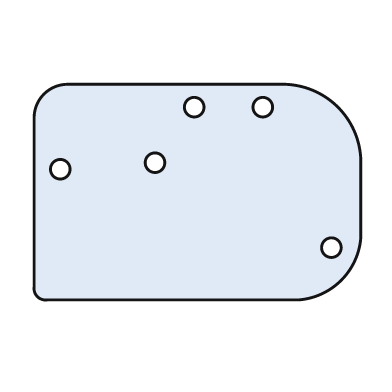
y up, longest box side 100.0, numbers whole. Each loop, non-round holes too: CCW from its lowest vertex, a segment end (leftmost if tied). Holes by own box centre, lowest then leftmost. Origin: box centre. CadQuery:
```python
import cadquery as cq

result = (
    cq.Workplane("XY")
    .moveTo(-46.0, -33.0)
    .lineTo(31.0, -33.0)
    .threePointArc((44.0, -27.0), (50.0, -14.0))
    .lineTo(50.0, 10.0)
    .threePointArc((43.0, 26.0), (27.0, 33.0))
    .lineTo(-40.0, 33.0)
    .threePointArc((-47.0, 30.0), (-50.0, 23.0))
    .lineTo(-50.0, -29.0)
    .threePointArc((-49.0, -32.0), (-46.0, -33.0))
    .close()
    .moveTo(41.0, -17.0)
    .circle(3.0)
    .moveTo(-42.0, 7.0)
    .circle(3.0)
    .moveTo(-13.0, 9.0)
    .circle(3.0)
    .moveTo(-1.0, 26.0)
    .circle(3.0)
    .moveTo(20.0, 26.0)
    .circle(3.0)
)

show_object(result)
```